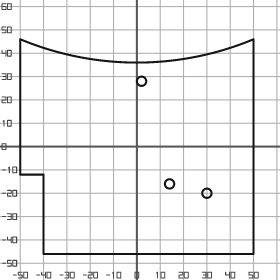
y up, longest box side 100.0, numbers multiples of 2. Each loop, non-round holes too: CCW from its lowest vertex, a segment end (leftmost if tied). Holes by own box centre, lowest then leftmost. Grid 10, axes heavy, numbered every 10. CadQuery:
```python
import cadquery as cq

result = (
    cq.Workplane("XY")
    .moveTo(-40.0, -46.0)
    .lineTo(50.0, -46.0)
    .lineTo(50.0, 46.0)
    .threePointArc((0.0, 36.0), (-50.0, 46.0))
    .lineTo(-50.0, -12.0)
    .lineTo(-40.0, -12.0)
    .close()
    .moveTo(30.0, -20.0)
    .circle(2.0)
    .moveTo(14.0, -16.0)
    .circle(2.0)
    .moveTo(2.0, 28.0)
    .circle(2.0)
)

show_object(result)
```